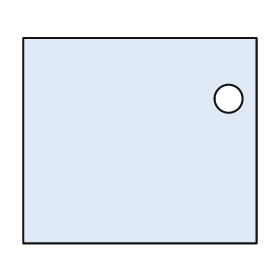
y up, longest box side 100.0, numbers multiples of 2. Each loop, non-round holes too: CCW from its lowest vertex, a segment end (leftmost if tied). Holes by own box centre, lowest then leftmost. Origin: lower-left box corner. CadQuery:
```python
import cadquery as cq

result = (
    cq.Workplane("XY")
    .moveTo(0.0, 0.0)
    .lineTo(100.0, 0.0)
    .lineTo(100.0, 88.0)
    .lineTo(0.0, 88.0)
    .close()
    .moveTo(88.0, 62.0)
    .circle(6.0)
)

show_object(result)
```